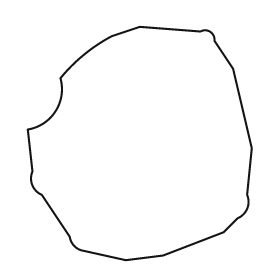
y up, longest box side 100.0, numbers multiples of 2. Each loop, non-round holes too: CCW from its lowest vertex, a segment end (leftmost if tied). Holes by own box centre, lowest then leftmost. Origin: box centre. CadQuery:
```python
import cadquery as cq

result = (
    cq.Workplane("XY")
    .moveTo(-6.0, -50.0)
    .lineTo(10.0, -48.0)
    .lineTo(36.0, -38.0)
    .lineTo(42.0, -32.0)
    .threePointArc((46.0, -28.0), (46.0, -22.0))
    .lineTo(48.0, -2.0)
    .lineTo(40.0, 32.0)
    .lineTo(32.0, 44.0)
    .threePointArc((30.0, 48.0), (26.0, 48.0))
    .lineTo(0.0, 50.0)
    .lineTo(-12.0, 46.0)
    .threePointArc((-24.0, 38.0), (-34.0, 28.0))
    .threePointArc((-36.0, 14.0), (-48.0, 6.0))
    .lineTo(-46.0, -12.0)
    .threePointArc((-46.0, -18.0), (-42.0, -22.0))
    .lineTo(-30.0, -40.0)
    .threePointArc((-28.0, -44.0), (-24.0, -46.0))
    .close()
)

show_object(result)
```